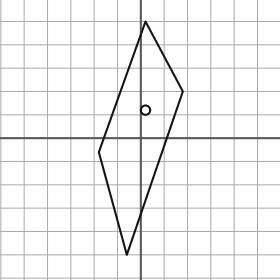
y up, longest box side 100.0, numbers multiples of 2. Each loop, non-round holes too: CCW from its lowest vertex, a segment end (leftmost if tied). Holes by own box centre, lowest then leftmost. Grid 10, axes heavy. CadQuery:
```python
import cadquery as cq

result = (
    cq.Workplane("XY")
    .moveTo(-6.0, -50.0)
    .lineTo(18.0, 20.0)
    .lineTo(2.0, 50.0)
    .lineTo(-18.0, -6.0)
    .close()
    .moveTo(2.0, 12.0)
    .circle(2.0)
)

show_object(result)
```